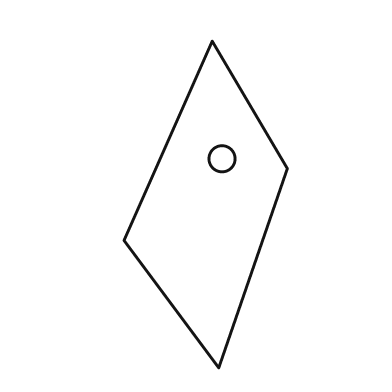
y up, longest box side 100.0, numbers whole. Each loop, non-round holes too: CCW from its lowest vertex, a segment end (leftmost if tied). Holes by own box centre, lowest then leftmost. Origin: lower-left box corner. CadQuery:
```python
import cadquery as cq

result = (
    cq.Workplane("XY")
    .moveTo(29.0, 0.0)
    .lineTo(50.0, 61.0)
    .lineTo(27.0, 100.0)
    .lineTo(0.0, 39.0)
    .close()
    .moveTo(30.0, 64.0)
    .circle(4.0)
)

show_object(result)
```